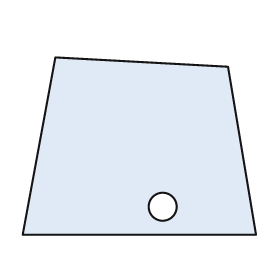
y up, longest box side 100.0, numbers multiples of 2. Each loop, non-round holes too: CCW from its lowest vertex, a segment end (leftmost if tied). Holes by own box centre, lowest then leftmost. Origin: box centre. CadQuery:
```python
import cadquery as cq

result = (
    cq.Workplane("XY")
    .moveTo(-50.0, -38.0)
    .lineTo(50.0, -38.0)
    .lineTo(38.0, 34.0)
    .lineTo(-36.0, 38.0)
    .close()
    .moveTo(10.0, -26.0)
    .circle(6.0)
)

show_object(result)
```